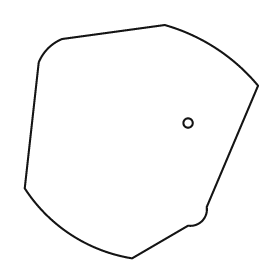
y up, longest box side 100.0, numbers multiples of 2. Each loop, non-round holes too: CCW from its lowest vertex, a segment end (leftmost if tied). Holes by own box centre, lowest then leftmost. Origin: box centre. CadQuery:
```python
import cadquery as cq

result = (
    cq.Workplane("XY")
    .moveTo(-4.0, -50.0)
    .lineTo(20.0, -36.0)
    .threePointArc((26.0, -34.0), (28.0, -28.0))
    .lineTo(50.0, 24.0)
    .threePointArc((32.0, 40.0), (10.0, 50.0))
    .lineTo(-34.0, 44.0)
    .threePointArc((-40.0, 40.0), (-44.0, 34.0))
    .lineTo(-50.0, -20.0)
    .threePointArc((-30.0, -40.0), (-4.0, -50.0))
    .close()
    .moveTo(20.0, 8.0)
    .circle(2.0)
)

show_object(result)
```